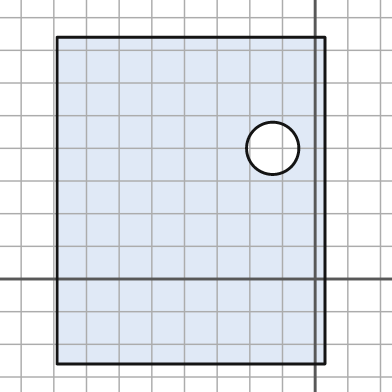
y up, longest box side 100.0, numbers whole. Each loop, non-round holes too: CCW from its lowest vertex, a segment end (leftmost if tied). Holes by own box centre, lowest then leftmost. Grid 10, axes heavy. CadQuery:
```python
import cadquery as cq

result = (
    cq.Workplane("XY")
    .moveTo(-79.0, -26.0)
    .lineTo(3.0, -26.0)
    .lineTo(3.0, 74.0)
    .lineTo(-79.0, 74.0)
    .close()
    .moveTo(-13.0, 40.0)
    .circle(8.0)
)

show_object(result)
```